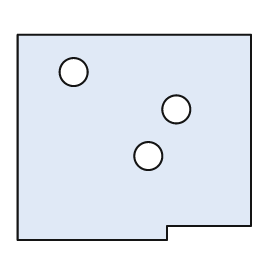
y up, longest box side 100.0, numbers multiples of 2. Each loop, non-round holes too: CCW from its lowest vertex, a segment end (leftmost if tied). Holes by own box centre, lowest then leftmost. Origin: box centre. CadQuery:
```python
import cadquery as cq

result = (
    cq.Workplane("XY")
    .moveTo(-50.0, -44.0)
    .lineTo(14.0, -44.0)
    .lineTo(14.0, -38.0)
    .lineTo(50.0, -38.0)
    .lineTo(50.0, 44.0)
    .lineTo(-50.0, 44.0)
    .close()
    .moveTo(6.0, -8.0)
    .circle(6.0)
    .moveTo(18.0, 12.0)
    .circle(6.0)
    .moveTo(-26.0, 28.0)
    .circle(6.0)
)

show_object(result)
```